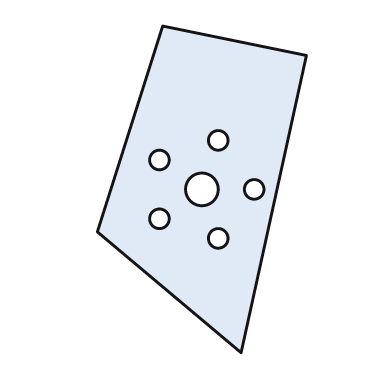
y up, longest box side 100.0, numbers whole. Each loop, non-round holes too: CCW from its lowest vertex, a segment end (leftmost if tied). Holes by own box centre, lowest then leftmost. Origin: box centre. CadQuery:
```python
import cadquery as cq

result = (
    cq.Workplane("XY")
    .moveTo(12.0, -50.0)
    .lineTo(32.0, 41.0)
    .lineTo(-12.0, 50.0)
    .lineTo(-32.0, -13.0)
    .close()
    .moveTo(5.0, -15.0)
    .circle(3.0)
    .moveTo(-13.0, -9.0)
    .circle(3.0)
    .moveTo(0.0, 0.0)
    .circle(5.0)
    .moveTo(16.0, 0.0)
    .circle(3.0)
    .moveTo(-13.0, 9.0)
    .circle(3.0)
    .moveTo(5.0, 15.0)
    .circle(3.0)
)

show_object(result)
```